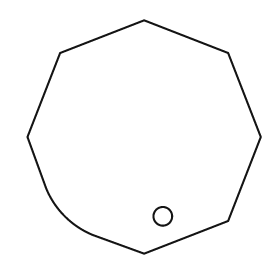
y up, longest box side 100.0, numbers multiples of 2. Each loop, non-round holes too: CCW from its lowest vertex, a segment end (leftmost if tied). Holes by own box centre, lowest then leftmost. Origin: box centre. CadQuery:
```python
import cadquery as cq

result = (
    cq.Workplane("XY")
    .moveTo(0.0, -50.0)
    .lineTo(36.0, -36.0)
    .lineTo(50.0, 0.0)
    .lineTo(36.0, 36.0)
    .lineTo(0.0, 50.0)
    .lineTo(-36.0, 36.0)
    .lineTo(-50.0, 0.0)
    .lineTo(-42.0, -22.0)
    .threePointArc((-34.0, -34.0), (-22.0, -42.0))
    .close()
    .moveTo(8.0, -34.0)
    .circle(4.0)
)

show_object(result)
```